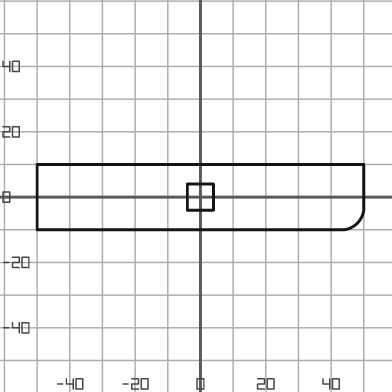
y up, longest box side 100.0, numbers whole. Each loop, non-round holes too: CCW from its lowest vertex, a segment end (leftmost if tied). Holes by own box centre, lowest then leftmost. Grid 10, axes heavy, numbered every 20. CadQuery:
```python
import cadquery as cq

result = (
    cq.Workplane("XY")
    .moveTo(-50.0, -10.0)
    .lineTo(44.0, -10.0)
    .threePointArc((48.0, -8.0), (50.0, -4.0))
    .lineTo(50.0, 10.0)
    .lineTo(-50.0, 10.0)
    .close()
    .moveTo(-4.0, -4.0)
    .lineTo(4.0, -4.0)
    .lineTo(4.0, 4.0)
    .lineTo(-4.0, 4.0)
    .close()
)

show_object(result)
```